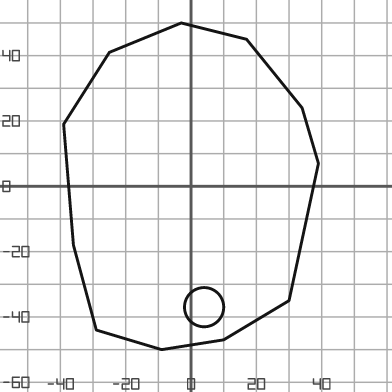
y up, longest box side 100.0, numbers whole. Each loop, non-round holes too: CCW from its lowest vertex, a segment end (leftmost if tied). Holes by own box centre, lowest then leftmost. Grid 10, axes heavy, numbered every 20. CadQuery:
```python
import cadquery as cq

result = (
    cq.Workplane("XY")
    .moveTo(-9.0, -50.0)
    .lineTo(10.0, -47.0)
    .lineTo(30.0, -35.0)
    .lineTo(39.0, 7.0)
    .lineTo(34.0, 24.0)
    .lineTo(17.0, 45.0)
    .lineTo(-3.0, 50.0)
    .lineTo(-25.0, 41.0)
    .lineTo(-39.0, 19.0)
    .lineTo(-36.0, -18.0)
    .lineTo(-29.0, -44.0)
    .close()
    .moveTo(4.0, -37.0)
    .circle(6.0)
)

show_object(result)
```